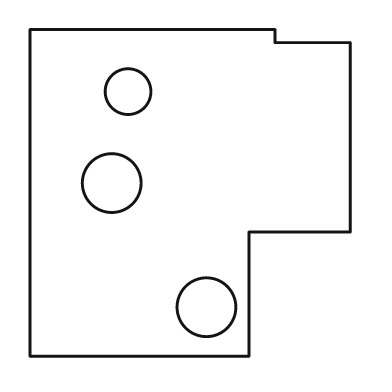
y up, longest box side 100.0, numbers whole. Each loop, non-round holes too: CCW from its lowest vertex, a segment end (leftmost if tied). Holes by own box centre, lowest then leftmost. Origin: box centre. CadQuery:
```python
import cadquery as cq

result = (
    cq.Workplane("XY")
    .moveTo(-49.0, -50.0)
    .lineTo(18.0, -50.0)
    .lineTo(18.0, -12.0)
    .lineTo(49.0, -12.0)
    .lineTo(49.0, 46.0)
    .lineTo(26.0, 46.0)
    .lineTo(26.0, 50.0)
    .lineTo(-49.0, 50.0)
    .close()
    .moveTo(5.0, -35.0)
    .circle(9.0)
    .moveTo(-24.0, 3.0)
    .circle(9.0)
    .moveTo(-19.0, 31.0)
    .circle(7.0)
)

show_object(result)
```